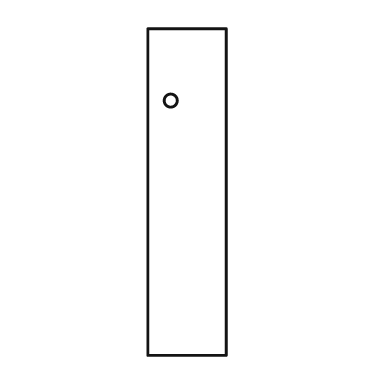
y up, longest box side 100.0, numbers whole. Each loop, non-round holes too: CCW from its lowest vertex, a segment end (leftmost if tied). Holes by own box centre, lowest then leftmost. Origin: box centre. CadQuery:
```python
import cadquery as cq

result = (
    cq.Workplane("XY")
    .moveTo(-12.0, -50.0)
    .lineTo(12.0, -50.0)
    .lineTo(12.0, 50.0)
    .lineTo(-12.0, 50.0)
    .close()
    .moveTo(-5.0, 28.0)
    .circle(2.0)
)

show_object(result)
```